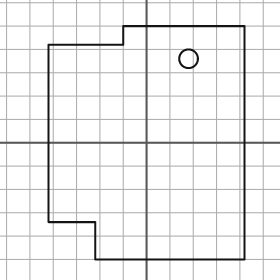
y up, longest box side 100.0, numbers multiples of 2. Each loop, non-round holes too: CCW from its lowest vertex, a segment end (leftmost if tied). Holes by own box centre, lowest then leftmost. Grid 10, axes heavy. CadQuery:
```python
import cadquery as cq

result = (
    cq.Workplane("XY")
    .moveTo(-22.0, -50.0)
    .lineTo(42.0, -50.0)
    .lineTo(42.0, 50.0)
    .lineTo(-10.0, 50.0)
    .lineTo(-10.0, 42.0)
    .lineTo(-42.0, 42.0)
    .lineTo(-42.0, -34.0)
    .lineTo(-22.0, -34.0)
    .close()
    .moveTo(18.0, 36.0)
    .circle(4.0)
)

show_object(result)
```